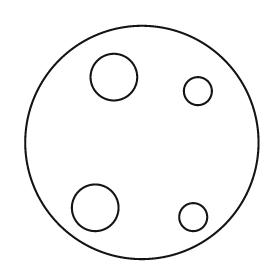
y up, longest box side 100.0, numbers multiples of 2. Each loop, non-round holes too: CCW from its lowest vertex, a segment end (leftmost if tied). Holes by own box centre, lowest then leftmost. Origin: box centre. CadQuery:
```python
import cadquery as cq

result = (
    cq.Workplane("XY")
    .moveTo(0.0, 0.0)
    .circle(50.0)
    .moveTo(22.0, -32.0)
    .circle(6.0)
    .moveTo(-20.0, -28.0)
    .circle(10.0)
    .moveTo(24.0, 22.0)
    .circle(6.0)
    .moveTo(-12.0, 28.0)
    .circle(10.0)
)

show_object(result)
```